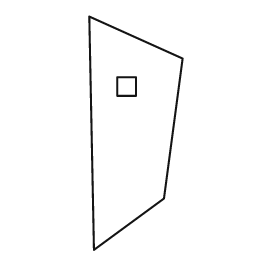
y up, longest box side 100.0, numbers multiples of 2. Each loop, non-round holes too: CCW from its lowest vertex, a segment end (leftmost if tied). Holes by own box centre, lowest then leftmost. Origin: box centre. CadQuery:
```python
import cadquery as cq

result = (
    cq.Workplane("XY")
    .moveTo(-18.0, -50.0)
    .lineTo(12.0, -28.0)
    .lineTo(20.0, 32.0)
    .lineTo(-20.0, 50.0)
    .close()
    .moveTo(-8.0, 16.0)
    .lineTo(0.0, 16.0)
    .lineTo(0.0, 24.0)
    .lineTo(-8.0, 24.0)
    .close()
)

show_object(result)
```